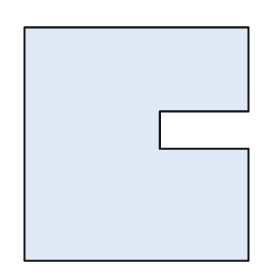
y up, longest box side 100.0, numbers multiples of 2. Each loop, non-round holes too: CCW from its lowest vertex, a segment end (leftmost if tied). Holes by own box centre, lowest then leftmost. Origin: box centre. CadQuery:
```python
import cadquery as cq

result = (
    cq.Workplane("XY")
    .moveTo(-48.0, -50.0)
    .lineTo(48.0, -50.0)
    .lineTo(48.0, -2.0)
    .lineTo(10.0, -2.0)
    .lineTo(10.0, 14.0)
    .lineTo(48.0, 14.0)
    .lineTo(48.0, 50.0)
    .lineTo(-48.0, 50.0)
    .close()
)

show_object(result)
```